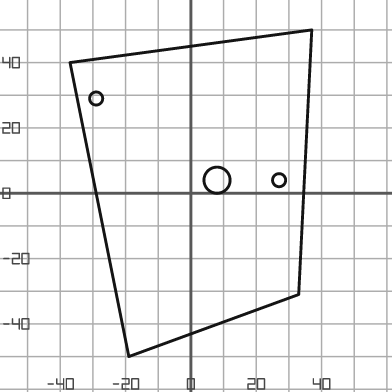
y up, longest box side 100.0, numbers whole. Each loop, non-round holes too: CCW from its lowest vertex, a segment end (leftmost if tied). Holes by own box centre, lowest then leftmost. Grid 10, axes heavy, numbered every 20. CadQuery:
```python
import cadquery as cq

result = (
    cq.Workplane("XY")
    .moveTo(-19.0, -50.0)
    .lineTo(33.0, -31.0)
    .lineTo(37.0, 50.0)
    .lineTo(-37.0, 40.0)
    .close()
    .moveTo(8.0, 4.0)
    .circle(4.0)
    .moveTo(27.0, 4.0)
    .circle(2.0)
    .moveTo(-29.0, 29.0)
    .circle(2.0)
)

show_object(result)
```